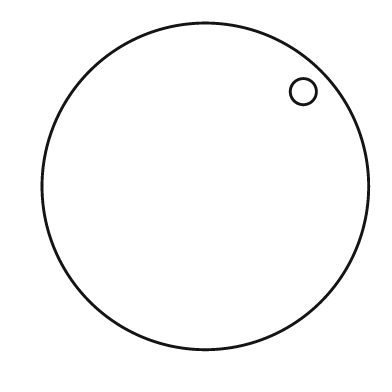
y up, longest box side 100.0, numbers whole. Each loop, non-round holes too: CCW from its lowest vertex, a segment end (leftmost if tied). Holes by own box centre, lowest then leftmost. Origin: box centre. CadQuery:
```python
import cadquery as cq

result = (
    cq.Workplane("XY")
    .moveTo(0.0, 0.0)
    .circle(50.0)
    .moveTo(30.0, 29.0)
    .circle(4.0)
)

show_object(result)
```